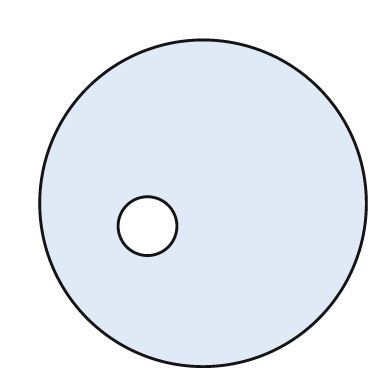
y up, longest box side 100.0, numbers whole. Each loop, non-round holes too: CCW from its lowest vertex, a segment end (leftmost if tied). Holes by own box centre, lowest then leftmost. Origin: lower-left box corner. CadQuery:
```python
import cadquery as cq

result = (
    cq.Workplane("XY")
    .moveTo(50.0, 50.0)
    .circle(50.0)
    .moveTo(33.0, 43.0)
    .circle(9.0)
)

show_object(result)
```